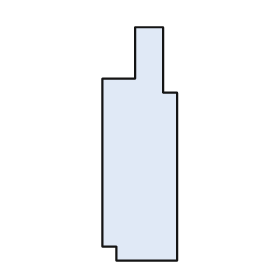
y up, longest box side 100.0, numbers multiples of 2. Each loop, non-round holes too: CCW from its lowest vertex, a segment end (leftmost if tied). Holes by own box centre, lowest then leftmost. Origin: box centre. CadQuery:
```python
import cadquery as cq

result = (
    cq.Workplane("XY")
    .moveTo(-10.0, -50.0)
    .lineTo(16.0, -50.0)
    .lineTo(16.0, 22.0)
    .lineTo(10.0, 22.0)
    .lineTo(10.0, 50.0)
    .lineTo(-2.0, 50.0)
    .lineTo(-2.0, 28.0)
    .lineTo(-16.0, 28.0)
    .lineTo(-16.0, -44.0)
    .lineTo(-10.0, -44.0)
    .close()
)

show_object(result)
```